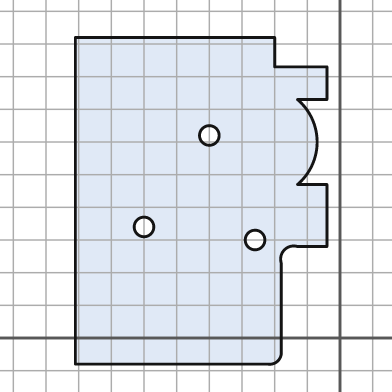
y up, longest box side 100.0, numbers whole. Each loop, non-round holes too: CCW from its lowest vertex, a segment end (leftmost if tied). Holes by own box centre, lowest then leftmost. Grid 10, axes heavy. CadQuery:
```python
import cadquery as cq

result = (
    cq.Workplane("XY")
    .moveTo(-81.0, -8.0)
    .lineTo(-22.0, -8.0)
    .threePointArc((-19.0, -7.0), (-18.0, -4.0))
    .lineTo(-18.0, 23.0)
    .threePointArc((-17.0, 27.0), (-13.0, 28.0))
    .lineTo(-4.0, 28.0)
    .lineTo(-4.0, 47.0)
    .lineTo(-13.0, 47.0)
    .threePointArc((-7.0, 60.0), (-13.0, 73.0))
    .lineTo(-4.0, 73.0)
    .lineTo(-4.0, 83.0)
    .lineTo(-20.0, 83.0)
    .lineTo(-20.0, 92.0)
    .lineTo(-81.0, 92.0)
    .close()
    .moveTo(-26.0, 30.0)
    .circle(3.0)
    .moveTo(-60.0, 34.0)
    .circle(3.0)
    .moveTo(-40.0, 62.0)
    .circle(3.0)
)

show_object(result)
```